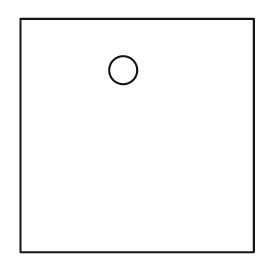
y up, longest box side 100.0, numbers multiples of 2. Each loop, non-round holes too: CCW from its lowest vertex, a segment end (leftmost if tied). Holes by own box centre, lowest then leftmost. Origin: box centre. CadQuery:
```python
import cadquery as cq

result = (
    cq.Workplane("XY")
    .moveTo(-50.0, -50.0)
    .lineTo(50.0, -50.0)
    .lineTo(50.0, 50.0)
    .lineTo(-50.0, 50.0)
    .close()
    .moveTo(-6.0, 28.0)
    .circle(6.0)
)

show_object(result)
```